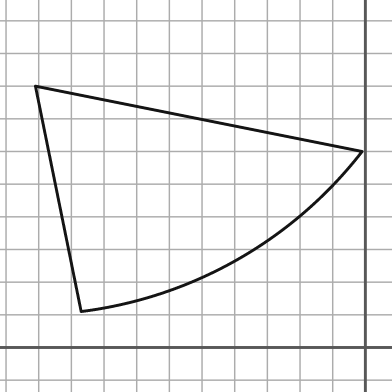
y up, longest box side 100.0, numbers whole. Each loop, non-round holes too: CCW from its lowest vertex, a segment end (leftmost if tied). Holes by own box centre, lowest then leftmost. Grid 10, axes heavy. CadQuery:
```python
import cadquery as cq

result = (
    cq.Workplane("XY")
    .moveTo(-87.0, 11.0)
    .threePointArc((-39.0, 27.0), (-1.0, 60.0))
    .lineTo(-101.0, 80.0)
    .close()
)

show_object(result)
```